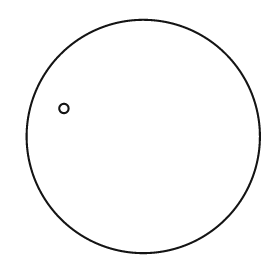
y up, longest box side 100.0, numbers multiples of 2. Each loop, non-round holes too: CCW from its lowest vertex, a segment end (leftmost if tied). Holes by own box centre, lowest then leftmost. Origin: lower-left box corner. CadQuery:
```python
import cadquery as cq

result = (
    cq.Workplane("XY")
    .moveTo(50.0, 50.0)
    .circle(50.0)
    .moveTo(16.0, 62.0)
    .circle(2.0)
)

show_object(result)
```